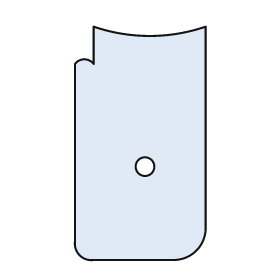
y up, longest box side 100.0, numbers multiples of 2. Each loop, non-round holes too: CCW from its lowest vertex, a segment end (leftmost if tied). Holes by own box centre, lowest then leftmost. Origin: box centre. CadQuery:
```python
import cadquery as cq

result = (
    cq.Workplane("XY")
    .moveTo(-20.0, -50.0)
    .lineTo(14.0, -50.0)
    .threePointArc((24.0, -46.0), (28.0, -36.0))
    .lineTo(28.0, 50.0)
    .threePointArc((4.0, 46.0), (-20.0, 50.0))
    .lineTo(-20.0, 34.0)
    .threePointArc((-24.0, 36.0), (-28.0, 34.0))
    .lineTo(-28.0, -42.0)
    .threePointArc((-26.0, -48.0), (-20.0, -50.0))
    .close()
    .moveTo(2.0, -10.0)
    .circle(4.0)
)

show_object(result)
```